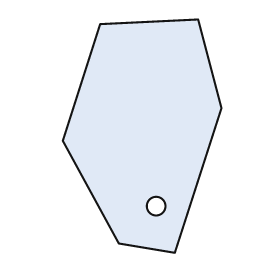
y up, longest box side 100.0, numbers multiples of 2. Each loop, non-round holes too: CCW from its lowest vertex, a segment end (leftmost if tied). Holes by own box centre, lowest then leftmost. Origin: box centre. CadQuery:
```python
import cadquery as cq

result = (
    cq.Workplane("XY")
    .moveTo(14.0, -50.0)
    .lineTo(34.0, 12.0)
    .lineTo(24.0, 50.0)
    .lineTo(-18.0, 48.0)
    .lineTo(-34.0, -2.0)
    .lineTo(-10.0, -46.0)
    .close()
    .moveTo(6.0, -30.0)
    .circle(4.0)
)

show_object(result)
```